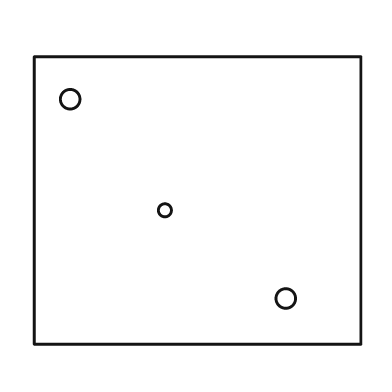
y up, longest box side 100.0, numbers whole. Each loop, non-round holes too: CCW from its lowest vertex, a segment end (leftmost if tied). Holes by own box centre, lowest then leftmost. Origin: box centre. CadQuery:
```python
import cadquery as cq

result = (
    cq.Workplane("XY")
    .moveTo(-50.0, -44.0)
    .lineTo(50.0, -44.0)
    .lineTo(50.0, 44.0)
    .lineTo(-50.0, 44.0)
    .close()
    .moveTo(27.0, -30.0)
    .circle(3.0)
    .moveTo(-10.0, -3.0)
    .circle(2.0)
    .moveTo(-39.0, 31.0)
    .circle(3.0)
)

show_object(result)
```